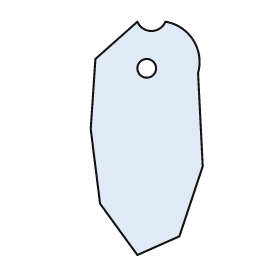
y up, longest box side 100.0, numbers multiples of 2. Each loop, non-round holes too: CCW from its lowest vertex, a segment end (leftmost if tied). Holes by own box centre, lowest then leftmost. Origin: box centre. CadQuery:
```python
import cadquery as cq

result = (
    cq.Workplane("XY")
    .moveTo(-4.0, -50.0)
    .lineTo(14.0, -42.0)
    .lineTo(24.0, -12.0)
    .lineTo(22.0, 28.0)
    .threePointArc((20.0, 42.0), (8.0, 50.0))
    .threePointArc((2.0, 46.0), (-4.0, 50.0))
    .lineTo(-22.0, 34.0)
    .lineTo(-24.0, 4.0)
    .lineTo(-20.0, -28.0)
    .close()
    .moveTo(0.0, 30.0)
    .circle(4.0)
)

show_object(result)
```